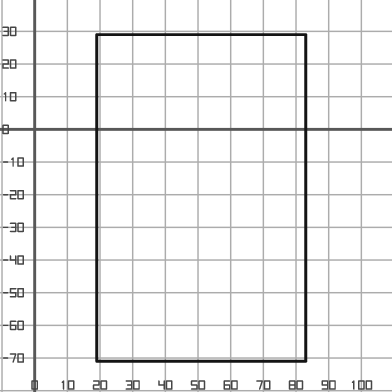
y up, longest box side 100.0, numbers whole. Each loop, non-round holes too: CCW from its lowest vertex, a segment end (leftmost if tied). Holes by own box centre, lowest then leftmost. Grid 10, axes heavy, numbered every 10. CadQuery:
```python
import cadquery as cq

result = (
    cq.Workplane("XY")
    .moveTo(19.0, -71.0)
    .lineTo(83.0, -71.0)
    .lineTo(83.0, 29.0)
    .lineTo(19.0, 29.0)
    .close()
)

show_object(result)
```